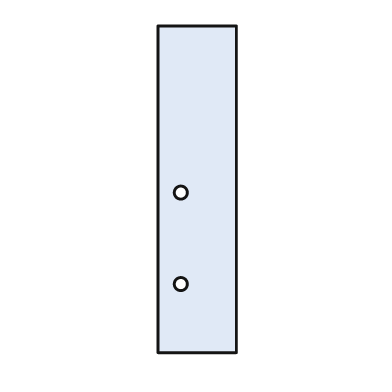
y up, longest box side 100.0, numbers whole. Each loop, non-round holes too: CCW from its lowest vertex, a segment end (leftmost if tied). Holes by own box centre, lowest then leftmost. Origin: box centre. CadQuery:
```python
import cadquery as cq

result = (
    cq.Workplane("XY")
    .moveTo(-12.0, -50.0)
    .lineTo(12.0, -50.0)
    .lineTo(12.0, 50.0)
    .lineTo(-12.0, 50.0)
    .close()
    .moveTo(-5.0, -29.0)
    .circle(2.0)
    .moveTo(-5.0, -1.0)
    .circle(2.0)
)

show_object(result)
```